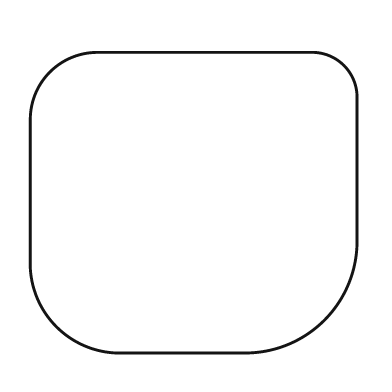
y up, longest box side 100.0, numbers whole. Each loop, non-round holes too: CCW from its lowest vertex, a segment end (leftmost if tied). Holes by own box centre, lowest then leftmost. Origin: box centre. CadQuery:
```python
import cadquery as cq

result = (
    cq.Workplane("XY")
    .moveTo(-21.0, -46.0)
    .lineTo(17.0, -46.0)
    .threePointArc((40.0, -36.0), (50.0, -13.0))
    .lineTo(50.0, 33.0)
    .threePointArc((46.0, 42.0), (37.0, 46.0))
    .lineTo(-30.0, 46.0)
    .threePointArc((-44.0, 40.0), (-50.0, 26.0))
    .lineTo(-50.0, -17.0)
    .threePointArc((-42.0, -38.0), (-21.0, -46.0))
    .close()
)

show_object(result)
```